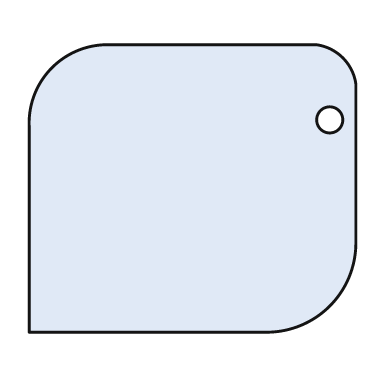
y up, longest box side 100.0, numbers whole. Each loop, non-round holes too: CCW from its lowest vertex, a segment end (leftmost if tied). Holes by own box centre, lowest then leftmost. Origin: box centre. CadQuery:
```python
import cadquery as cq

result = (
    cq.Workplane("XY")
    .moveTo(-50.0, -44.0)
    .lineTo(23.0, -44.0)
    .threePointArc((42.0, -36.0), (50.0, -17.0))
    .lineTo(50.0, 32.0)
    .threePointArc((46.0, 40.0), (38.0, 44.0))
    .lineTo(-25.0, 44.0)
    .threePointArc((-43.0, 37.0), (-50.0, 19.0))
    .close()
    .moveTo(42.0, 21.0)
    .circle(4.0)
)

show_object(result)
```